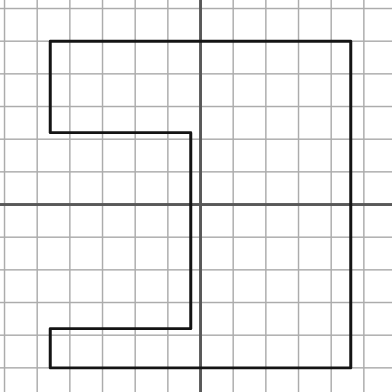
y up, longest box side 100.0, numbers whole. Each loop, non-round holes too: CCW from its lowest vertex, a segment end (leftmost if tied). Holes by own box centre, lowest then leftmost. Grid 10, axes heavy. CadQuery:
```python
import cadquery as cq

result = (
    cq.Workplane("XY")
    .moveTo(-46.0, -50.0)
    .lineTo(46.0, -50.0)
    .lineTo(46.0, 50.0)
    .lineTo(-46.0, 50.0)
    .lineTo(-46.0, 22.0)
    .lineTo(-3.0, 22.0)
    .lineTo(-3.0, -38.0)
    .lineTo(-46.0, -38.0)
    .close()
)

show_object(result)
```